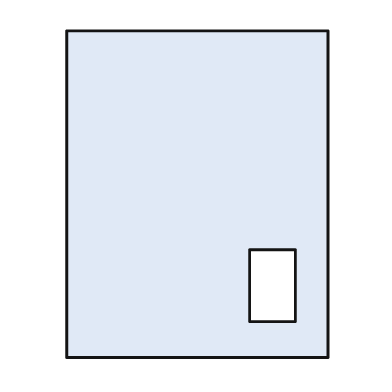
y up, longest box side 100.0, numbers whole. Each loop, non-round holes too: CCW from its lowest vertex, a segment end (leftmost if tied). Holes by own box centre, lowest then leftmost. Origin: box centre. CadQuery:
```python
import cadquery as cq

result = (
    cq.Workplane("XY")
    .moveTo(-40.0, -50.0)
    .lineTo(40.0, -50.0)
    .lineTo(40.0, 50.0)
    .lineTo(-40.0, 50.0)
    .close()
    .moveTo(16.0, -39.0)
    .lineTo(30.0, -39.0)
    .lineTo(30.0, -17.0)
    .lineTo(16.0, -17.0)
    .close()
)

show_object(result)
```